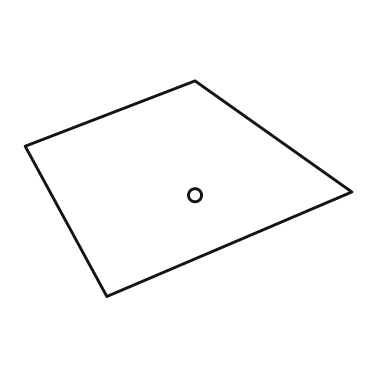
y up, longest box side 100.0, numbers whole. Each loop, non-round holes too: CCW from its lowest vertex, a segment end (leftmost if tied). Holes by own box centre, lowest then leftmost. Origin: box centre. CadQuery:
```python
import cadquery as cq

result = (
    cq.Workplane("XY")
    .moveTo(-25.0, -33.0)
    .lineTo(50.0, -1.0)
    .lineTo(2.0, 33.0)
    .lineTo(-50.0, 13.0)
    .close()
    .moveTo(2.0, -2.0)
    .circle(2.0)
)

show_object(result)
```